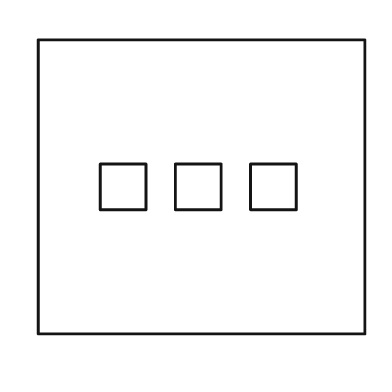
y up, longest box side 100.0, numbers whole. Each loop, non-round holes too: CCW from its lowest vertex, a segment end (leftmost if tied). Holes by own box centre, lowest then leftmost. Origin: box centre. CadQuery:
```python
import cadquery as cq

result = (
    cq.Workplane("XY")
    .moveTo(-50.0, -45.0)
    .lineTo(50.0, -45.0)
    .lineTo(50.0, 45.0)
    .lineTo(-50.0, 45.0)
    .close()
    .moveTo(-31.0, -7.0)
    .lineTo(-17.0, -7.0)
    .lineTo(-17.0, 7.0)
    .lineTo(-31.0, 7.0)
    .close()
    .moveTo(-8.0, -7.0)
    .lineTo(6.0, -7.0)
    .lineTo(6.0, 7.0)
    .lineTo(-8.0, 7.0)
    .close()
    .moveTo(15.0, -7.0)
    .lineTo(29.0, -7.0)
    .lineTo(29.0, 7.0)
    .lineTo(15.0, 7.0)
    .close()
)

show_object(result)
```